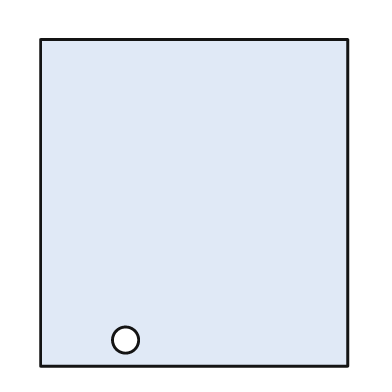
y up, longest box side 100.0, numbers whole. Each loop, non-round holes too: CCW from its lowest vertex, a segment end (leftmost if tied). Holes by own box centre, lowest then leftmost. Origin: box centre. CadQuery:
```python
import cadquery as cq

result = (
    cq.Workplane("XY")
    .moveTo(-47.0, -50.0)
    .lineTo(47.0, -50.0)
    .lineTo(47.0, 50.0)
    .lineTo(-47.0, 50.0)
    .close()
    .moveTo(-21.0, -42.0)
    .circle(4.0)
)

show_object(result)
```